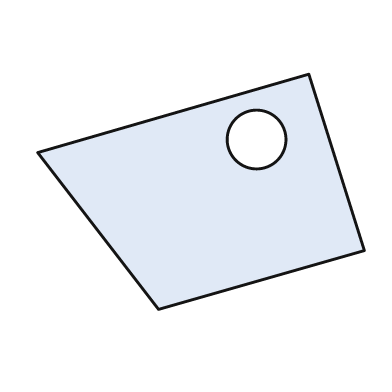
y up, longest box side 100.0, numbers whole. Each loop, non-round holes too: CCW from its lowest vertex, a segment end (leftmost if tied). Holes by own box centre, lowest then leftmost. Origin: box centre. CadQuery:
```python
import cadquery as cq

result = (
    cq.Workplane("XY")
    .moveTo(-13.0, -36.0)
    .lineTo(50.0, -18.0)
    .lineTo(33.0, 36.0)
    .lineTo(-50.0, 12.0)
    .close()
    .moveTo(17.0, 16.0)
    .circle(9.0)
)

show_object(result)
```